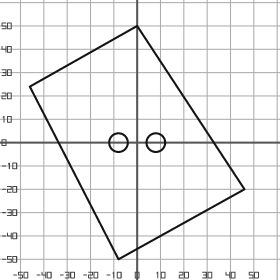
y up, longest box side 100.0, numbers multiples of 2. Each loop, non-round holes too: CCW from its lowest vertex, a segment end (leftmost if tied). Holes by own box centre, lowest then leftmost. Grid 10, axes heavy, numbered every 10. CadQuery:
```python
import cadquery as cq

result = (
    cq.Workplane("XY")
    .moveTo(-8.0, -50.0)
    .lineTo(46.0, -20.0)
    .lineTo(0.0, 50.0)
    .lineTo(-46.0, 24.0)
    .close()
    .moveTo(-8.0, 0.0)
    .circle(4.0)
    .moveTo(8.0, 0.0)
    .circle(4.0)
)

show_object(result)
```